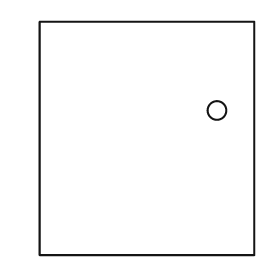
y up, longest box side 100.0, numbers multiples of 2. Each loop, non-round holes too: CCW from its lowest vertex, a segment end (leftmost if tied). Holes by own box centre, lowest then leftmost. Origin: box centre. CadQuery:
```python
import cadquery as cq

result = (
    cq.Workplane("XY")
    .moveTo(-46.0, -50.0)
    .lineTo(46.0, -50.0)
    .lineTo(46.0, 50.0)
    .lineTo(-46.0, 50.0)
    .close()
    .moveTo(30.0, 12.0)
    .circle(4.0)
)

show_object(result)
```